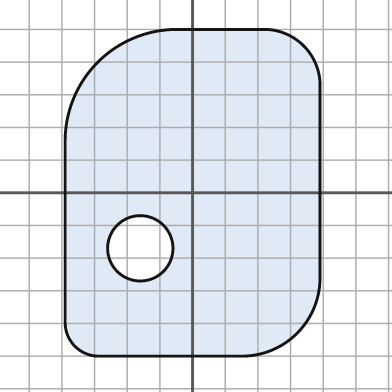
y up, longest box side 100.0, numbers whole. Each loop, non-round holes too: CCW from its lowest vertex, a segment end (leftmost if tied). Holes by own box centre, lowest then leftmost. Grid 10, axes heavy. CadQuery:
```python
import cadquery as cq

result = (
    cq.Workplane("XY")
    .moveTo(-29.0, -50.0)
    .lineTo(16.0, -50.0)
    .threePointArc((32.0, -43.0), (39.0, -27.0))
    .lineTo(39.0, 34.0)
    .threePointArc((34.0, 45.0), (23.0, 50.0))
    .lineTo(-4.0, 50.0)
    .threePointArc((-29.0, 40.0), (-39.0, 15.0))
    .lineTo(-39.0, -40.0)
    .threePointArc((-36.0, -47.0), (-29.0, -50.0))
    .close()
    .moveTo(-16.0, -17.0)
    .circle(10.0)
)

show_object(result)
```